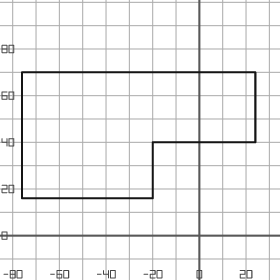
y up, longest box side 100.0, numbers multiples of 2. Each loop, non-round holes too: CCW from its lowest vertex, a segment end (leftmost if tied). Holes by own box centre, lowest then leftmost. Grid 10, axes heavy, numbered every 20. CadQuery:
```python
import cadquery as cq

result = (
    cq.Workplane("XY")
    .moveTo(-76.0, 16.0)
    .lineTo(-20.0, 16.0)
    .lineTo(-20.0, 40.0)
    .lineTo(24.0, 40.0)
    .lineTo(24.0, 70.0)
    .lineTo(-76.0, 70.0)
    .close()
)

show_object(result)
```